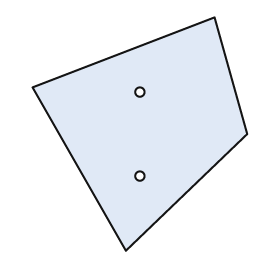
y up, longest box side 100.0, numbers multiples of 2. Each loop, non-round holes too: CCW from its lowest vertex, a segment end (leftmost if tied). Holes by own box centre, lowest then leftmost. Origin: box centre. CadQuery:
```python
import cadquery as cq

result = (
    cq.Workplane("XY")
    .moveTo(-6.0, -50.0)
    .lineTo(46.0, 0.0)
    .lineTo(32.0, 50.0)
    .lineTo(-46.0, 20.0)
    .close()
    .moveTo(0.0, -18.0)
    .circle(2.0)
    .moveTo(0.0, 18.0)
    .circle(2.0)
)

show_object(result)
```